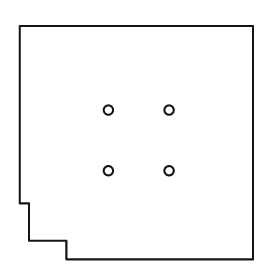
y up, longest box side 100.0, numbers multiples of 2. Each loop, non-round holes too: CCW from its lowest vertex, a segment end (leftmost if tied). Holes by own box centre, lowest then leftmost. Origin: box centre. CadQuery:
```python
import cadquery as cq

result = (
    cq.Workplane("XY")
    .moveTo(-30.0, -50.0)
    .lineTo(50.0, -50.0)
    .lineTo(50.0, 50.0)
    .lineTo(-50.0, 50.0)
    .lineTo(-50.0, -26.0)
    .lineTo(-46.0, -26.0)
    .lineTo(-46.0, -42.0)
    .lineTo(-30.0, -42.0)
    .close()
    .moveTo(-12.0, -12.0)
    .circle(2.0)
    .moveTo(14.0, -12.0)
    .circle(2.0)
    .moveTo(-12.0, 14.0)
    .circle(2.0)
    .moveTo(14.0, 14.0)
    .circle(2.0)
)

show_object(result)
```